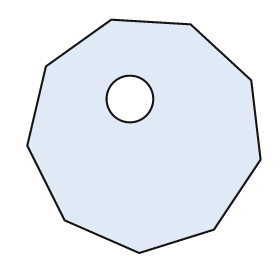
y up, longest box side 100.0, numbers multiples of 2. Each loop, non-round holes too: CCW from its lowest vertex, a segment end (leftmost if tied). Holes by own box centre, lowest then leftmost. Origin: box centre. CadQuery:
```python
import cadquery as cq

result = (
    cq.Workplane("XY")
    .moveTo(-2.0, -50.0)
    .lineTo(30.0, -40.0)
    .lineTo(50.0, -10.0)
    .lineTo(46.0, 24.0)
    .lineTo(20.0, 48.0)
    .lineTo(-14.0, 50.0)
    .lineTo(-42.0, 30.0)
    .lineTo(-50.0, -4.0)
    .lineTo(-34.0, -36.0)
    .close()
    .moveTo(-6.0, 16.0)
    .circle(10.0)
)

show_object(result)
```